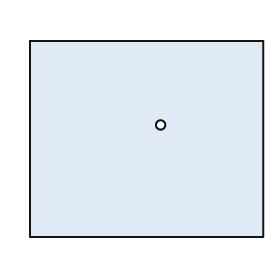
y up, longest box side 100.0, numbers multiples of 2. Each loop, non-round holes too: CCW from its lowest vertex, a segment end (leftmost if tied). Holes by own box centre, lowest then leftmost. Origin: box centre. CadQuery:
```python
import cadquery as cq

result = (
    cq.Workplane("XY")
    .moveTo(-50.0, -42.0)
    .lineTo(50.0, -42.0)
    .lineTo(50.0, 42.0)
    .lineTo(-50.0, 42.0)
    .close()
    .moveTo(6.0, 6.0)
    .circle(2.0)
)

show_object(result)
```